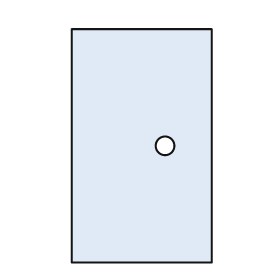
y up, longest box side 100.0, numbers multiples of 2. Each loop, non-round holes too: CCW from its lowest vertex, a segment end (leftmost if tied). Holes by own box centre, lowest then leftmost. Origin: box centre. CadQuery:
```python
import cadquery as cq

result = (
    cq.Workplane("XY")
    .moveTo(-30.0, -50.0)
    .lineTo(30.0, -50.0)
    .lineTo(30.0, 50.0)
    .lineTo(-30.0, 50.0)
    .close()
    .moveTo(10.0, 0.0)
    .circle(4.0)
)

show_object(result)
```